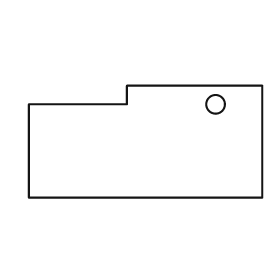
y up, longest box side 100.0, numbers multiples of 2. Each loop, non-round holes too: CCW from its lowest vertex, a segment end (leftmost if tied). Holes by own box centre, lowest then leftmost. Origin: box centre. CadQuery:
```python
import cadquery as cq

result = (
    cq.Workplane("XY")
    .moveTo(-50.0, -24.0)
    .lineTo(50.0, -24.0)
    .lineTo(50.0, 24.0)
    .lineTo(-8.0, 24.0)
    .lineTo(-8.0, 16.0)
    .lineTo(-50.0, 16.0)
    .close()
    .moveTo(30.0, 16.0)
    .circle(4.0)
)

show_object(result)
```